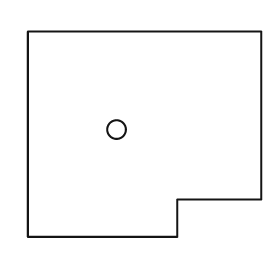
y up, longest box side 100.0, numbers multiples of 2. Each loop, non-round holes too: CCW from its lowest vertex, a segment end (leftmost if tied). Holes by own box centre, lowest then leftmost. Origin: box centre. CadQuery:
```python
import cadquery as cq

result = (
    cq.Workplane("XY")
    .moveTo(-50.0, -44.0)
    .lineTo(14.0, -44.0)
    .lineTo(14.0, -28.0)
    .lineTo(50.0, -28.0)
    .lineTo(50.0, 44.0)
    .lineTo(-50.0, 44.0)
    .close()
    .moveTo(-12.0, 2.0)
    .circle(4.0)
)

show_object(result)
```